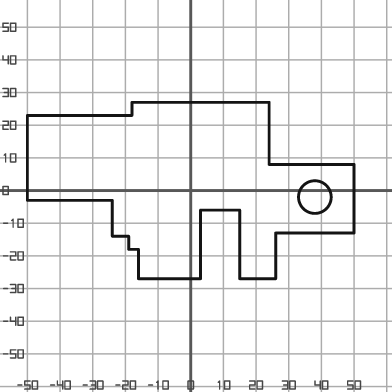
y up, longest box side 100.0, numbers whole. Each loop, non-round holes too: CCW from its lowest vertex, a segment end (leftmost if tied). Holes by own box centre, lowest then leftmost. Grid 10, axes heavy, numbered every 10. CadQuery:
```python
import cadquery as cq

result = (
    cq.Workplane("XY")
    .moveTo(-16.0, -27.0)
    .lineTo(3.0, -27.0)
    .lineTo(3.0, -6.0)
    .lineTo(15.0, -6.0)
    .lineTo(15.0, -27.0)
    .lineTo(26.0, -27.0)
    .lineTo(26.0, -13.0)
    .lineTo(50.0, -13.0)
    .lineTo(50.0, 8.0)
    .lineTo(24.0, 8.0)
    .lineTo(24.0, 27.0)
    .lineTo(-18.0, 27.0)
    .lineTo(-18.0, 23.0)
    .lineTo(-50.0, 23.0)
    .lineTo(-50.0, -3.0)
    .lineTo(-24.0, -3.0)
    .lineTo(-24.0, -14.0)
    .lineTo(-19.0, -14.0)
    .lineTo(-19.0, -18.0)
    .lineTo(-16.0, -18.0)
    .close()
    .moveTo(38.0, -2.0)
    .circle(5.0)
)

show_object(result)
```